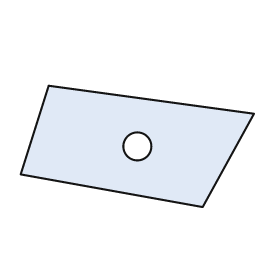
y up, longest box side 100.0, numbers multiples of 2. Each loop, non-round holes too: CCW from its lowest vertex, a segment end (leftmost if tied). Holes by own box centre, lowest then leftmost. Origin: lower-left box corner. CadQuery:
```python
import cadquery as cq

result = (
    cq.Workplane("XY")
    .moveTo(78.0, 0.0)
    .lineTo(100.0, 40.0)
    .lineTo(12.0, 52.0)
    .lineTo(0.0, 14.0)
    .close()
    .moveTo(50.0, 26.0)
    .circle(6.0)
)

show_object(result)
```